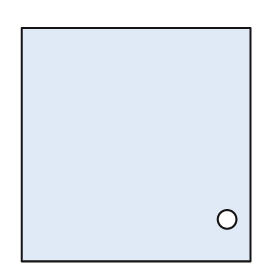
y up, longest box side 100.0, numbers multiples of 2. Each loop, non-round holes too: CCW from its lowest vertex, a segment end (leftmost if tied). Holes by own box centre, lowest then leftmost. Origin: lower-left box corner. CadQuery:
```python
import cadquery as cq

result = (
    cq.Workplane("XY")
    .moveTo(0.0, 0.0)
    .lineTo(98.0, 0.0)
    .lineTo(98.0, 100.0)
    .lineTo(0.0, 100.0)
    .close()
    .moveTo(88.0, 18.0)
    .circle(4.0)
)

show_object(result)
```